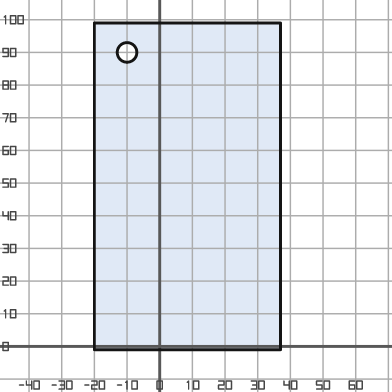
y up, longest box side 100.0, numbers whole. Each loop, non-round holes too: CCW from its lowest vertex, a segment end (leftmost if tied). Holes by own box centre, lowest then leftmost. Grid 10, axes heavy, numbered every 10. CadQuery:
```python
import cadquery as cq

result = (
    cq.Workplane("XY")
    .moveTo(-20.0, -1.0)
    .lineTo(37.0, -1.0)
    .lineTo(37.0, 99.0)
    .lineTo(-20.0, 99.0)
    .close()
    .moveTo(-10.0, 90.0)
    .circle(3.0)
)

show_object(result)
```